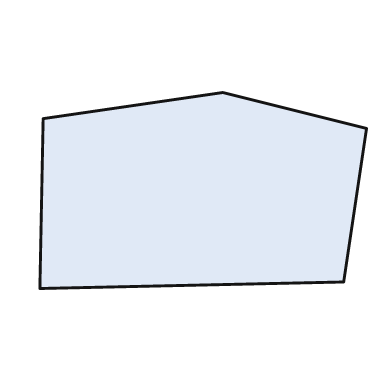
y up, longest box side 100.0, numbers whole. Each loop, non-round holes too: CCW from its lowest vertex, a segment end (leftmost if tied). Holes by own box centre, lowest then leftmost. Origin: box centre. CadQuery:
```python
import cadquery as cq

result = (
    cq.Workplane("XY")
    .moveTo(-50.0, -30.0)
    .lineTo(43.0, -28.0)
    .lineTo(50.0, 19.0)
    .lineTo(6.0, 30.0)
    .lineTo(-49.0, 22.0)
    .close()
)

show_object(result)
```